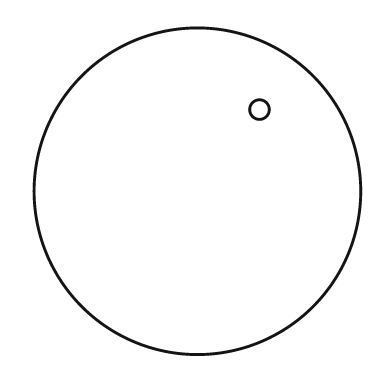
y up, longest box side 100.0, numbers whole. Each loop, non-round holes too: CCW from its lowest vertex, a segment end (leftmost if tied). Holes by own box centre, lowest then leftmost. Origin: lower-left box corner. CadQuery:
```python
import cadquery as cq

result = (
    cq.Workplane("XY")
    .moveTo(50.0, 50.0)
    .circle(50.0)
    .moveTo(69.0, 75.0)
    .circle(3.0)
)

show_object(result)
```